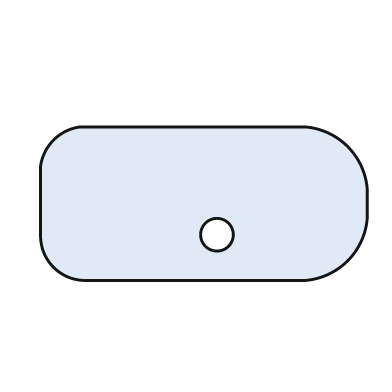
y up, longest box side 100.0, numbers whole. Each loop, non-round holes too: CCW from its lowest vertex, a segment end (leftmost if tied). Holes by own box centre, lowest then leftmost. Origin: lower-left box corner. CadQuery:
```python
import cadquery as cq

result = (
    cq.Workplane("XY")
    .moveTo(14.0, 0.0)
    .lineTo(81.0, 0.0)
    .threePointArc((94.0, 6.0), (100.0, 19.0))
    .lineTo(100.0, 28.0)
    .threePointArc((94.0, 41.0), (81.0, 47.0))
    .lineTo(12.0, 47.0)
    .threePointArc((4.0, 43.0), (0.0, 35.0))
    .lineTo(0.0, 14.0)
    .threePointArc((4.0, 4.0), (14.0, 0.0))
    .close()
    .moveTo(54.0, 14.0)
    .circle(5.0)
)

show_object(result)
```